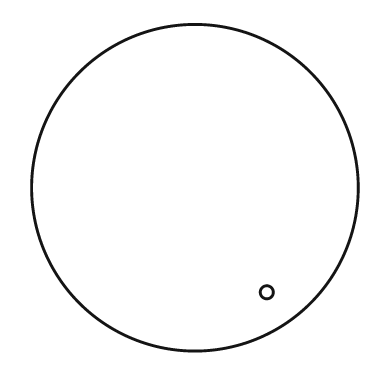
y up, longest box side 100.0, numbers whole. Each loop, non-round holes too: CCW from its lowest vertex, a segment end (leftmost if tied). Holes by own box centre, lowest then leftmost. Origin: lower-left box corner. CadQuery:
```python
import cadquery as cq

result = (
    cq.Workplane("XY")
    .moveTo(50.0, 50.0)
    .circle(50.0)
    .moveTo(72.0, 18.0)
    .circle(2.0)
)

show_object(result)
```